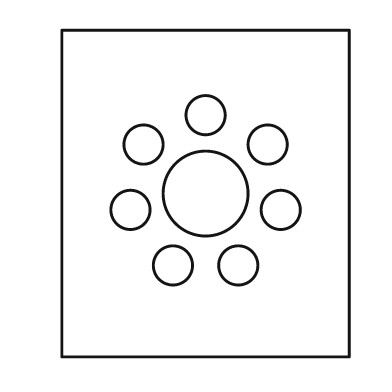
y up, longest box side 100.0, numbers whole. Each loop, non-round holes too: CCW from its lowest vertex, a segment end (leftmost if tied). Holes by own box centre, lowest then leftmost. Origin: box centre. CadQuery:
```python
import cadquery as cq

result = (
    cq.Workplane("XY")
    .moveTo(-44.0, -50.0)
    .lineTo(44.0, -50.0)
    .lineTo(44.0, 50.0)
    .lineTo(-44.0, 50.0)
    .close()
    .moveTo(-10.0, -22.0)
    .circle(6.0)
    .moveTo(10.0, -22.0)
    .circle(6.0)
    .moveTo(-23.0, -5.0)
    .circle(6.0)
    .moveTo(23.0, -5.0)
    .circle(6.0)
    .moveTo(0.0, 0.0)
    .circle(13.0)
    .moveTo(-19.0, 15.0)
    .circle(6.0)
    .moveTo(19.0, 15.0)
    .circle(6.0)
    .moveTo(0.0, 24.0)
    .circle(6.0)
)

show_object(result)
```